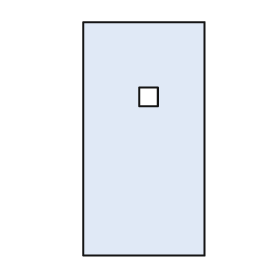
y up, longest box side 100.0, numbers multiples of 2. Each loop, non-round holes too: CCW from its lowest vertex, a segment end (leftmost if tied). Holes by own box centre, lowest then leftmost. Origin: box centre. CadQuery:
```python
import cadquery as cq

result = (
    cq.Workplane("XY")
    .moveTo(-26.0, -50.0)
    .lineTo(26.0, -50.0)
    .lineTo(26.0, 50.0)
    .lineTo(-26.0, 50.0)
    .close()
    .moveTo(-2.0, 14.0)
    .lineTo(6.0, 14.0)
    .lineTo(6.0, 22.0)
    .lineTo(-2.0, 22.0)
    .close()
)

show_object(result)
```